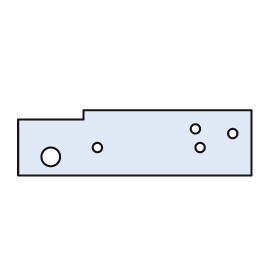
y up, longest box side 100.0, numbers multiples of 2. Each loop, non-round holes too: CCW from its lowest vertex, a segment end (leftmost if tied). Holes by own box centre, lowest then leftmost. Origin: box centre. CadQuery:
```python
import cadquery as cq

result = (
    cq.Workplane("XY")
    .moveTo(-50.0, -14.0)
    .lineTo(50.0, -14.0)
    .lineTo(50.0, 14.0)
    .lineTo(-22.0, 14.0)
    .lineTo(-22.0, 10.0)
    .lineTo(-50.0, 10.0)
    .close()
    .moveTo(-36.0, -6.0)
    .circle(4.0)
    .moveTo(-16.0, -2.0)
    .circle(2.0)
    .moveTo(28.0, -2.0)
    .circle(2.0)
    .moveTo(42.0, 4.0)
    .circle(2.0)
    .moveTo(26.0, 6.0)
    .circle(2.0)
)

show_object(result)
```